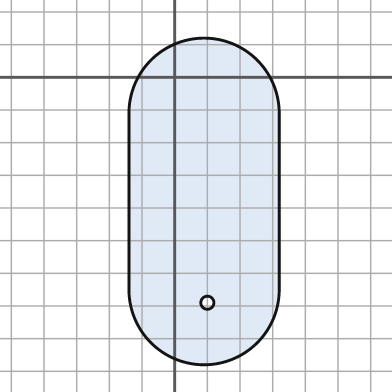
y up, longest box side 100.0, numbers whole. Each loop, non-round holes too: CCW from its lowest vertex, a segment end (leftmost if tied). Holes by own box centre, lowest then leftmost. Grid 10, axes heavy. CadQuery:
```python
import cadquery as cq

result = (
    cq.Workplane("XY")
    .moveTo(-14.0, -65.0)
    .threePointArc((9.0, -88.0), (32.0, -65.0))
    .lineTo(32.0, -11.0)
    .threePointArc((9.0, 12.0), (-14.0, -11.0))
    .close()
    .moveTo(10.0, -69.0)
    .circle(2.0)
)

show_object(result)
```